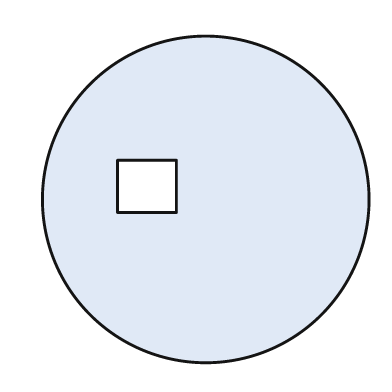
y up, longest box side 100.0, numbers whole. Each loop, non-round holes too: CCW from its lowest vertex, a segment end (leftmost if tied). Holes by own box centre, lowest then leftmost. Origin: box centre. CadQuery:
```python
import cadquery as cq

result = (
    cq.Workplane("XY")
    .moveTo(0.0, 0.0)
    .circle(50.0)
    .moveTo(-27.0, -4.0)
    .lineTo(-9.0, -4.0)
    .lineTo(-9.0, 12.0)
    .lineTo(-27.0, 12.0)
    .close()
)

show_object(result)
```